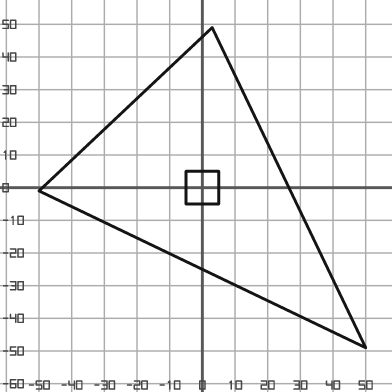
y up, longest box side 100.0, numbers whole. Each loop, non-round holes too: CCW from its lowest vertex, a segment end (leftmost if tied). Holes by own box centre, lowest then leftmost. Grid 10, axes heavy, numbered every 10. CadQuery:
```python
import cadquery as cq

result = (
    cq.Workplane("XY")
    .moveTo(50.0, -49.0)
    .lineTo(3.0, 49.0)
    .lineTo(-50.0, -1.0)
    .close()
    .moveTo(-5.0, -5.0)
    .lineTo(5.0, -5.0)
    .lineTo(5.0, 5.0)
    .lineTo(-5.0, 5.0)
    .close()
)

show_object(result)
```